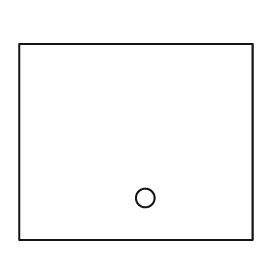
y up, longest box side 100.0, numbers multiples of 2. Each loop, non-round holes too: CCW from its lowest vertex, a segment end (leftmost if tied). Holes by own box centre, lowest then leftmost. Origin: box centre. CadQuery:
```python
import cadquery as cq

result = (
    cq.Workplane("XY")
    .moveTo(-50.0, -42.0)
    .lineTo(50.0, -42.0)
    .lineTo(50.0, 42.0)
    .lineTo(-50.0, 42.0)
    .close()
    .moveTo(4.0, -24.0)
    .circle(4.0)
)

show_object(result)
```